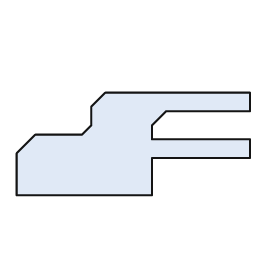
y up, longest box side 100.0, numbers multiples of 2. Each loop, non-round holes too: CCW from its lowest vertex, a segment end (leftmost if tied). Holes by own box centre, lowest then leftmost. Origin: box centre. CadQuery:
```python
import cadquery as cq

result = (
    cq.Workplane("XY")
    .moveTo(-50.0, -22.0)
    .lineTo(8.0, -22.0)
    .lineTo(8.0, -6.0)
    .lineTo(50.0, -6.0)
    .lineTo(50.0, 2.0)
    .lineTo(8.0, 2.0)
    .lineTo(8.0, 8.0)
    .lineTo(14.0, 14.0)
    .lineTo(50.0, 14.0)
    .lineTo(50.0, 22.0)
    .lineTo(-12.0, 22.0)
    .lineTo(-18.0, 16.0)
    .lineTo(-18.0, 8.0)
    .lineTo(-22.0, 4.0)
    .lineTo(-42.0, 4.0)
    .lineTo(-50.0, -4.0)
    .close()
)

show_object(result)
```